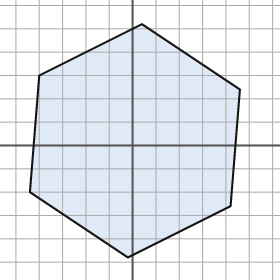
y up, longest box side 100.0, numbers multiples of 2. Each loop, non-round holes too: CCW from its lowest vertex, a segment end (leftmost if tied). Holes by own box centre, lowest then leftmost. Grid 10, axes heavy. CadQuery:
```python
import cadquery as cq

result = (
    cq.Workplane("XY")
    .moveTo(-2.0, -48.0)
    .lineTo(42.0, -26.0)
    .lineTo(46.0, 24.0)
    .lineTo(4.0, 52.0)
    .lineTo(-40.0, 30.0)
    .lineTo(-44.0, -20.0)
    .close()
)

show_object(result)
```